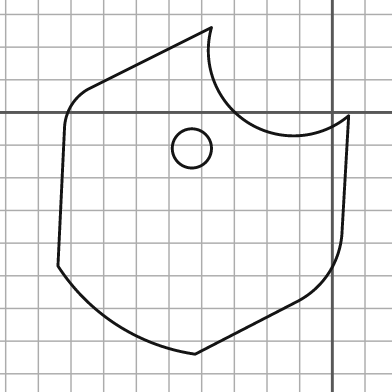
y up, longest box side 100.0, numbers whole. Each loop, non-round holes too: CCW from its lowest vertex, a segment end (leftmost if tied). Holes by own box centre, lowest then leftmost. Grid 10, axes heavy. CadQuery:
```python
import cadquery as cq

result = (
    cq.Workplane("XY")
    .moveTo(-42.0, -74.0)
    .lineTo(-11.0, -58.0)
    .threePointArc((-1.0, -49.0), (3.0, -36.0))
    .lineTo(5.0, -1.0)
    .threePointArc((-26.0, -3.0), (-37.0, 26.0))
    .lineTo(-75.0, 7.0)
    .threePointArc((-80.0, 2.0), (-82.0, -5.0))
    .lineTo(-84.0, -47.0)
    .threePointArc((-66.0, -65.0), (-42.0, -74.0))
    .close()
    .moveTo(-43.0, -11.0)
    .circle(6.0)
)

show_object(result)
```